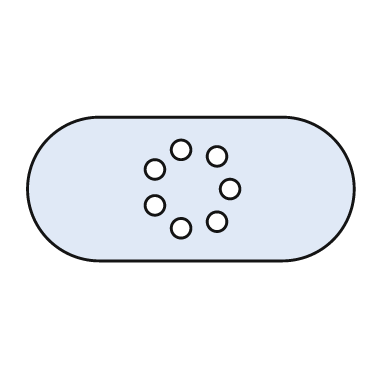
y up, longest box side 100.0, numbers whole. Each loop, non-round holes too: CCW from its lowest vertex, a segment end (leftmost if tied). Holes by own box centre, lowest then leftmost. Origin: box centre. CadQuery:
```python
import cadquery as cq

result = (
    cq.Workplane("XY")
    .moveTo(-28.0, -22.0)
    .lineTo(28.0, -22.0)
    .threePointArc((50.0, 0.0), (28.0, 22.0))
    .lineTo(-28.0, 22.0)
    .threePointArc((-50.0, 0.0), (-28.0, -22.0))
    .close()
    .moveTo(-3.0, -12.0)
    .circle(3.0)
    .moveTo(8.0, -10.0)
    .circle(3.0)
    .moveTo(-11.0, -5.0)
    .circle(3.0)
    .moveTo(12.0, 0.0)
    .circle(3.0)
    .moveTo(-11.0, 6.0)
    .circle(3.0)
    .moveTo(8.0, 10.0)
    .circle(3.0)
    .moveTo(-3.0, 12.0)
    .circle(3.0)
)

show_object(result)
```